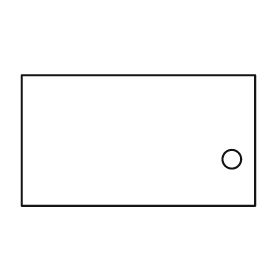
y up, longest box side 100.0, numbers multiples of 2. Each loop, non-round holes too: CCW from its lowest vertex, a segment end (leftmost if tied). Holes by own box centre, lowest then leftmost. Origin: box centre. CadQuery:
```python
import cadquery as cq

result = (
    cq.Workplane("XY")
    .moveTo(-50.0, -28.0)
    .lineTo(50.0, -28.0)
    .lineTo(50.0, 28.0)
    .lineTo(-50.0, 28.0)
    .close()
    .moveTo(40.0, -8.0)
    .circle(4.0)
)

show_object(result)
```